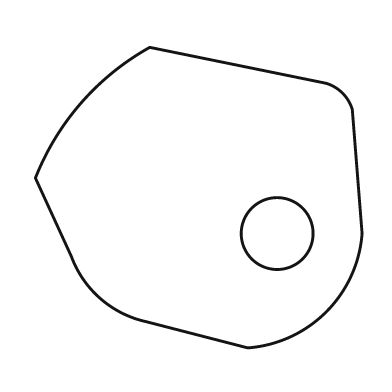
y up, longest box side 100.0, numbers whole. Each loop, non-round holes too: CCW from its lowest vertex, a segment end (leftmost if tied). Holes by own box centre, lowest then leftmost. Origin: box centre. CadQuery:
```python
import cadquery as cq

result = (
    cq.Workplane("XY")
    .moveTo(15.0, -46.0)
    .threePointArc((39.0, -35.0), (50.0, -11.0))
    .lineTo(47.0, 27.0)
    .threePointArc((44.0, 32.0), (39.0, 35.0))
    .lineTo(-15.0, 46.0)
    .threePointArc((-36.0, 29.0), (-50.0, 6.0))
    .lineTo(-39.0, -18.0)
    .threePointArc((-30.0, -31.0), (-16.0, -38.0))
    .close()
    .moveTo(24.0, -11.0)
    .circle(11.0)
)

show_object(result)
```